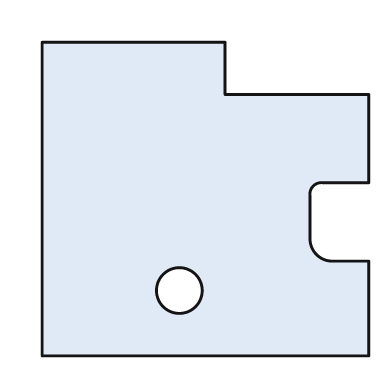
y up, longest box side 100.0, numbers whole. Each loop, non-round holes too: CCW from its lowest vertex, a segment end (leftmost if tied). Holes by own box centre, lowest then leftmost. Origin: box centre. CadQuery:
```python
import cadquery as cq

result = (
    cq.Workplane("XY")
    .moveTo(-50.0, -48.0)
    .lineTo(50.0, -48.0)
    .lineTo(50.0, -19.0)
    .lineTo(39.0, -19.0)
    .threePointArc((34.0, -17.0), (32.0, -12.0))
    .lineTo(32.0, 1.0)
    .threePointArc((33.0, 4.0), (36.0, 5.0))
    .lineTo(50.0, 5.0)
    .lineTo(50.0, 32.0)
    .lineTo(6.0, 32.0)
    .lineTo(6.0, 48.0)
    .lineTo(-50.0, 48.0)
    .close()
    .moveTo(-8.0, -28.0)
    .circle(7.0)
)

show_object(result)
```